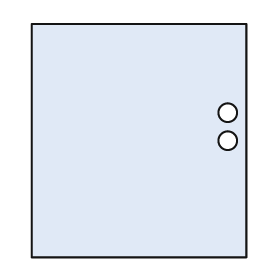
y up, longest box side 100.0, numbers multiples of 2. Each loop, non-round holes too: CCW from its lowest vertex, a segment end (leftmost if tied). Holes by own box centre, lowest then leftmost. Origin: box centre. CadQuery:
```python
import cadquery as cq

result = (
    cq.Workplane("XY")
    .moveTo(-46.0, -50.0)
    .lineTo(46.0, -50.0)
    .lineTo(46.0, 50.0)
    .lineTo(-46.0, 50.0)
    .close()
    .moveTo(38.0, 0.0)
    .circle(4.0)
    .moveTo(38.0, 12.0)
    .circle(4.0)
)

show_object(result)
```